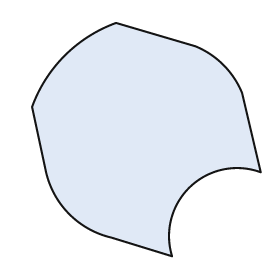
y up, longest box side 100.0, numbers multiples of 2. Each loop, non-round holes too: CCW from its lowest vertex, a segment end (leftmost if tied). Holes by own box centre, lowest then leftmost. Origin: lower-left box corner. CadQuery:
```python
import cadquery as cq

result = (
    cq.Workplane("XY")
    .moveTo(60.0, 0.0)
    .threePointArc((68.0, 30.0), (98.0, 36.0))
    .lineTo(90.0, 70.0)
    .threePointArc((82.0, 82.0), (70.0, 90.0))
    .lineTo(36.0, 100.0)
    .threePointArc((14.0, 86.0), (0.0, 64.0))
    .lineTo(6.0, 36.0)
    .threePointArc((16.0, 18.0), (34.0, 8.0))
    .close()
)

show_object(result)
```